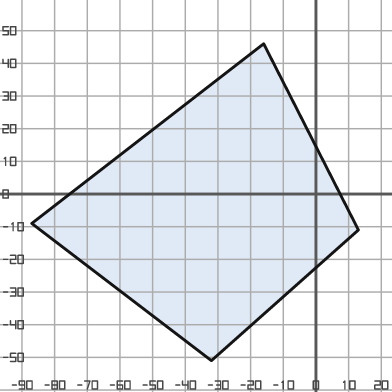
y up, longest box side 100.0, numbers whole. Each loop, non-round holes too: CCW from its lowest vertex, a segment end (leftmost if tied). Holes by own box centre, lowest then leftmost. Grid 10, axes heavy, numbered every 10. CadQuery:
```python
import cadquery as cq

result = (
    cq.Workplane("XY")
    .moveTo(-32.0, -51.0)
    .lineTo(13.0, -11.0)
    .lineTo(-16.0, 46.0)
    .lineTo(-87.0, -9.0)
    .close()
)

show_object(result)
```